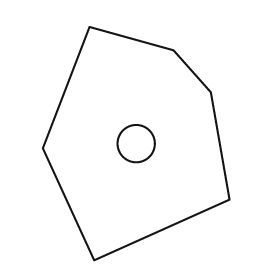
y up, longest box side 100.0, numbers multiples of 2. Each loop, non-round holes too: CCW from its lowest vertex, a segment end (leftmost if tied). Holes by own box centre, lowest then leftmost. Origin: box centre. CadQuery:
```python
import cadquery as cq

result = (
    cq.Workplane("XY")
    .moveTo(-18.0, -50.0)
    .lineTo(40.0, -24.0)
    .lineTo(32.0, 22.0)
    .lineTo(16.0, 40.0)
    .lineTo(-20.0, 50.0)
    .lineTo(-40.0, -2.0)
    .close()
    .moveTo(0.0, 0.0)
    .circle(8.0)
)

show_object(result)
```